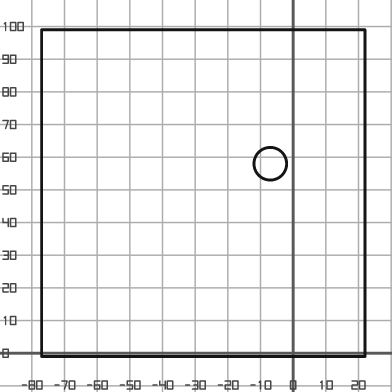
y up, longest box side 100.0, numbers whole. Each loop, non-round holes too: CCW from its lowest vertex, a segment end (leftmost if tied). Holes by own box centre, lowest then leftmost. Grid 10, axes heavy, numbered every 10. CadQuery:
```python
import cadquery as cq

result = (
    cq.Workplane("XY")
    .moveTo(-77.0, -1.0)
    .lineTo(22.0, -1.0)
    .lineTo(22.0, 99.0)
    .lineTo(-77.0, 99.0)
    .close()
    .moveTo(-7.0, 58.0)
    .circle(5.0)
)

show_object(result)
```